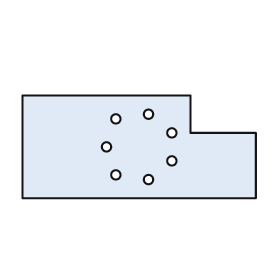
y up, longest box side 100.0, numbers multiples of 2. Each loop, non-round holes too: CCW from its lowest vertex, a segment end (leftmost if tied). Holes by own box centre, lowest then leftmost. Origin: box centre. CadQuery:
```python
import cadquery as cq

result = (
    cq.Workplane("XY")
    .moveTo(-50.0, -22.0)
    .lineTo(50.0, -22.0)
    .lineTo(50.0, 6.0)
    .lineTo(22.0, 6.0)
    .lineTo(22.0, 22.0)
    .lineTo(-50.0, 22.0)
    .close()
    .moveTo(4.0, -14.0)
    .circle(2.0)
    .moveTo(-10.0, -12.0)
    .circle(2.0)
    .moveTo(14.0, -6.0)
    .circle(2.0)
    .moveTo(-14.0, 0.0)
    .circle(2.0)
    .moveTo(14.0, 6.0)
    .circle(2.0)
    .moveTo(-10.0, 12.0)
    .circle(2.0)
    .moveTo(4.0, 14.0)
    .circle(2.0)
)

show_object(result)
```